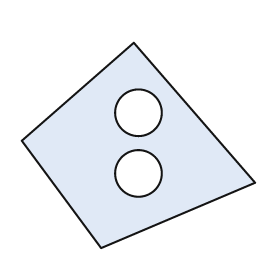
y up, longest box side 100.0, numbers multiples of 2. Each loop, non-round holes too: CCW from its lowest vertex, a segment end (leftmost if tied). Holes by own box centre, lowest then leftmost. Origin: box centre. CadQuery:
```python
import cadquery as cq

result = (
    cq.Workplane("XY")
    .moveTo(-16.0, -44.0)
    .lineTo(50.0, -16.0)
    .lineTo(-2.0, 44.0)
    .lineTo(-50.0, 2.0)
    .close()
    .moveTo(0.0, -12.0)
    .circle(10.0)
    .moveTo(0.0, 14.0)
    .circle(10.0)
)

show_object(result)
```